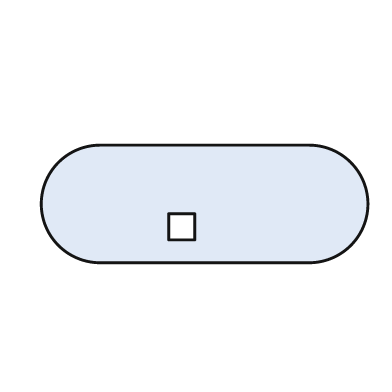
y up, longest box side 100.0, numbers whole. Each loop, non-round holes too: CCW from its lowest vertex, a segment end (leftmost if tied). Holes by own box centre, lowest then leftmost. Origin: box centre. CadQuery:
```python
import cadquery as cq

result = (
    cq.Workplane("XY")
    .moveTo(-32.0, -18.0)
    .lineTo(32.0, -18.0)
    .threePointArc((50.0, 0.0), (32.0, 18.0))
    .lineTo(-32.0, 18.0)
    .threePointArc((-50.0, 0.0), (-32.0, -18.0))
    .close()
    .moveTo(-11.0, -11.0)
    .lineTo(-3.0, -11.0)
    .lineTo(-3.0, -3.0)
    .lineTo(-11.0, -3.0)
    .close()
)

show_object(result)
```